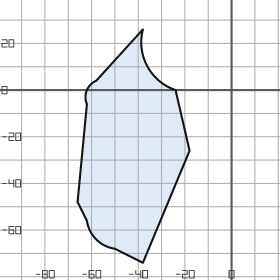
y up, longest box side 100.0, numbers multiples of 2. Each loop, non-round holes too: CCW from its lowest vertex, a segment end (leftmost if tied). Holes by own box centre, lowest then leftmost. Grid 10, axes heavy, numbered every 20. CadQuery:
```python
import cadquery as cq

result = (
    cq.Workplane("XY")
    .moveTo(-38.0, -74.0)
    .lineTo(-18.0, -26.0)
    .lineTo(-24.0, 0.0)
    .threePointArc((-36.0, 10.0), (-38.0, 26.0))
    .lineTo(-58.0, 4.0)
    .threePointArc((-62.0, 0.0), (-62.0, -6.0))
    .lineTo(-66.0, -48.0)
    .lineTo(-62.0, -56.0)
    .threePointArc((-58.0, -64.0), (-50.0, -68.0))
    .close()
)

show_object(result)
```